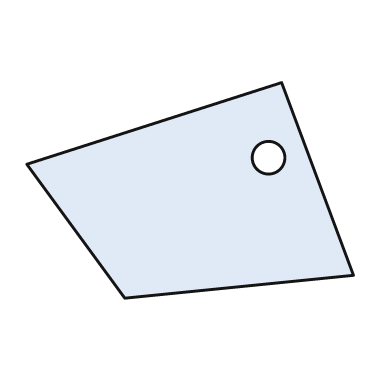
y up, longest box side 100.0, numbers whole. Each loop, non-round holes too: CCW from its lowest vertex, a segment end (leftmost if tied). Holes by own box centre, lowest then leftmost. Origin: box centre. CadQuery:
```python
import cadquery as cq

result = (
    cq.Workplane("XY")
    .moveTo(-20.0, -33.0)
    .lineTo(50.0, -26.0)
    .lineTo(28.0, 33.0)
    .lineTo(-50.0, 8.0)
    .close()
    .moveTo(24.0, 10.0)
    .circle(5.0)
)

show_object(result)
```